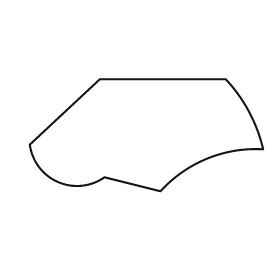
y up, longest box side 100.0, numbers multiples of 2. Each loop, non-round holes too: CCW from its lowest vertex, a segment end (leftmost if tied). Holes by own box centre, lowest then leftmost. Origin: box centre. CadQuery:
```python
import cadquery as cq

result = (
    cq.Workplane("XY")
    .moveTo(6.0, -24.0)
    .threePointArc((26.0, -10.0), (50.0, -6.0))
    .threePointArc((44.0, 10.0), (34.0, 24.0))
    .lineTo(-20.0, 24.0)
    .lineTo(-50.0, -4.0)
    .threePointArc((-38.0, -20.0), (-18.0, -18.0))
    .close()
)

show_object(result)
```